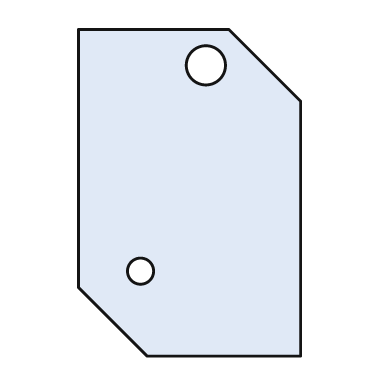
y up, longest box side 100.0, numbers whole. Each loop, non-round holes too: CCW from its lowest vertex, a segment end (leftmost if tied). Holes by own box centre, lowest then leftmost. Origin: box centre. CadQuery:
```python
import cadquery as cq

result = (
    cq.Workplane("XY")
    .moveTo(-13.0, -50.0)
    .lineTo(34.0, -50.0)
    .lineTo(34.0, 28.0)
    .lineTo(12.0, 50.0)
    .lineTo(-34.0, 50.0)
    .lineTo(-34.0, -29.0)
    .close()
    .moveTo(-15.0, -24.0)
    .circle(4.0)
    .moveTo(5.0, 39.0)
    .circle(6.0)
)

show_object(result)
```